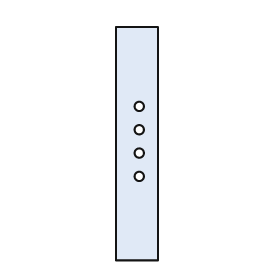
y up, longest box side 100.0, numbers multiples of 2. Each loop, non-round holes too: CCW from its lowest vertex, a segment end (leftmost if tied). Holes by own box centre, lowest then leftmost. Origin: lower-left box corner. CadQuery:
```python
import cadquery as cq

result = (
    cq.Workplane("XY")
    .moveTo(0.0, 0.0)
    .lineTo(18.0, 0.0)
    .lineTo(18.0, 100.0)
    .lineTo(0.0, 100.0)
    .close()
    .moveTo(10.0, 36.0)
    .circle(2.0)
    .moveTo(10.0, 46.0)
    .circle(2.0)
    .moveTo(10.0, 56.0)
    .circle(2.0)
    .moveTo(10.0, 66.0)
    .circle(2.0)
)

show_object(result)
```